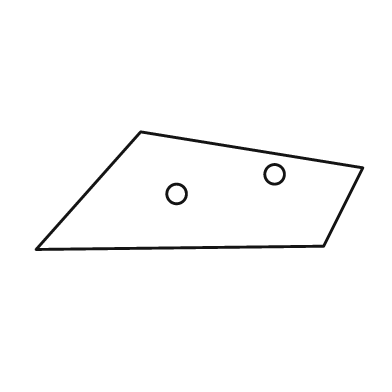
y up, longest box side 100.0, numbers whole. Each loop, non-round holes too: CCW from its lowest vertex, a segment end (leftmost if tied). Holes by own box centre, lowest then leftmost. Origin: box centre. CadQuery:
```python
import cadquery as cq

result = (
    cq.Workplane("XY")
    .moveTo(-50.0, -18.0)
    .lineTo(38.0, -17.0)
    .lineTo(50.0, 7.0)
    .lineTo(-18.0, 18.0)
    .close()
    .moveTo(-7.0, -1.0)
    .circle(3.0)
    .moveTo(23.0, 5.0)
    .circle(3.0)
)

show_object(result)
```